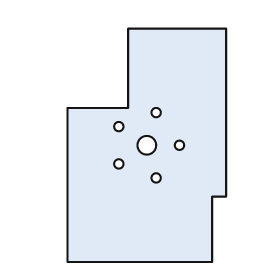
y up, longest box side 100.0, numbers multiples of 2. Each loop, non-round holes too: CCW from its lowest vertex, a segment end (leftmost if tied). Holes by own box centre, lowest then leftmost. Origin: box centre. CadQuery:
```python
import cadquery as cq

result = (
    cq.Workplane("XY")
    .moveTo(-34.0, -50.0)
    .lineTo(28.0, -50.0)
    .lineTo(28.0, -22.0)
    .lineTo(34.0, -22.0)
    .lineTo(34.0, 50.0)
    .lineTo(-8.0, 50.0)
    .lineTo(-8.0, 16.0)
    .lineTo(-34.0, 16.0)
    .close()
    .moveTo(4.0, -14.0)
    .circle(2.0)
    .moveTo(-12.0, -8.0)
    .circle(2.0)
    .moveTo(0.0, 0.0)
    .circle(4.0)
    .moveTo(14.0, 0.0)
    .circle(2.0)
    .moveTo(-12.0, 8.0)
    .circle(2.0)
    .moveTo(4.0, 14.0)
    .circle(2.0)
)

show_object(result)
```